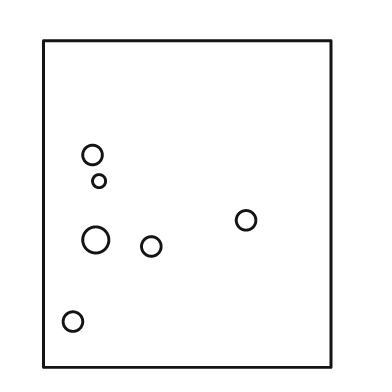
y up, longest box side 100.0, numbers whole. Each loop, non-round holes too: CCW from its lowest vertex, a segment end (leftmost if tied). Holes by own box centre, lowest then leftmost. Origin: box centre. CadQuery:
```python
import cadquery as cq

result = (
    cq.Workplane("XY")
    .moveTo(-44.0, -50.0)
    .lineTo(44.0, -50.0)
    .lineTo(44.0, 50.0)
    .lineTo(-44.0, 50.0)
    .close()
    .moveTo(-35.0, -36.0)
    .circle(3.0)
    .moveTo(-11.0, -13.0)
    .circle(3.0)
    .moveTo(-28.0, -11.0)
    .circle(4.0)
    .moveTo(18.0, -5.0)
    .circle(3.0)
    .moveTo(-27.0, 7.0)
    .circle(2.0)
    .moveTo(-29.0, 15.0)
    .circle(3.0)
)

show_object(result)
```